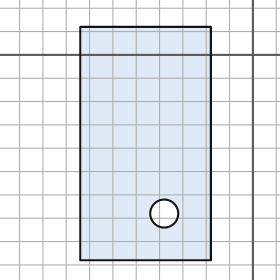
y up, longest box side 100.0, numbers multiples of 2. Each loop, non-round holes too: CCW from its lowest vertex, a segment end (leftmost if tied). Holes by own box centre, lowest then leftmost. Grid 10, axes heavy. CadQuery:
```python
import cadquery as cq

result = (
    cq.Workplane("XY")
    .moveTo(-74.0, -88.0)
    .lineTo(-18.0, -88.0)
    .lineTo(-18.0, 12.0)
    .lineTo(-74.0, 12.0)
    .close()
    .moveTo(-38.0, -68.0)
    .circle(6.0)
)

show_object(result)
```